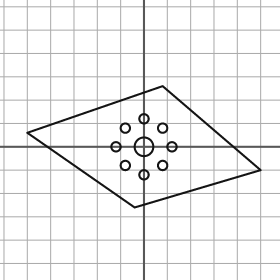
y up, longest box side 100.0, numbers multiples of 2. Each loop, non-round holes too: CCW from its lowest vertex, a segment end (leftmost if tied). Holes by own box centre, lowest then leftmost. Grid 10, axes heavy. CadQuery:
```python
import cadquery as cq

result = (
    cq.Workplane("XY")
    .moveTo(-4.0, -26.0)
    .lineTo(50.0, -10.0)
    .lineTo(8.0, 26.0)
    .lineTo(-50.0, 6.0)
    .close()
    .moveTo(0.0, -12.0)
    .circle(2.0)
    .moveTo(-8.0, -8.0)
    .circle(2.0)
    .moveTo(8.0, -8.0)
    .circle(2.0)
    .moveTo(-12.0, 0.0)
    .circle(2.0)
    .moveTo(0.0, 0.0)
    .circle(4.0)
    .moveTo(12.0, 0.0)
    .circle(2.0)
    .moveTo(-8.0, 8.0)
    .circle(2.0)
    .moveTo(8.0, 8.0)
    .circle(2.0)
    .moveTo(0.0, 12.0)
    .circle(2.0)
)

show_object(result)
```